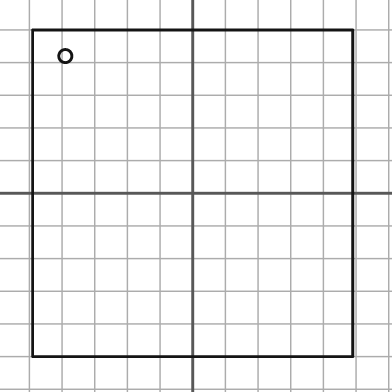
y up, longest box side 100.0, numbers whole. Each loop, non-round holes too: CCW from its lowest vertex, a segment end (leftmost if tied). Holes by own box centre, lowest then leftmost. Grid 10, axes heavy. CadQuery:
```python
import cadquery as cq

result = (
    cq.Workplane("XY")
    .moveTo(-49.0, -50.0)
    .lineTo(49.0, -50.0)
    .lineTo(49.0, 50.0)
    .lineTo(-49.0, 50.0)
    .close()
    .moveTo(-39.0, 42.0)
    .circle(2.0)
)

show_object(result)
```